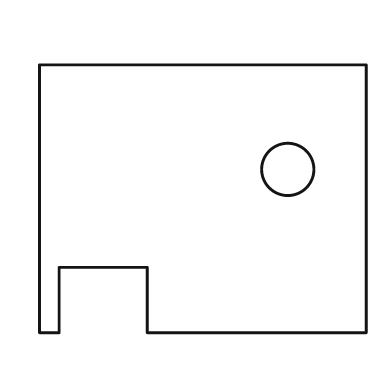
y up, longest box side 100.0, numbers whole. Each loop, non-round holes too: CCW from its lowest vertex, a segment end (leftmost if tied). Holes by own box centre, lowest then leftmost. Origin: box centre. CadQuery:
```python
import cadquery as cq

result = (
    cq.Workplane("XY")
    .moveTo(-50.0, -41.0)
    .lineTo(-44.0, -41.0)
    .lineTo(-44.0, -21.0)
    .lineTo(-17.0, -21.0)
    .lineTo(-17.0, -41.0)
    .lineTo(50.0, -41.0)
    .lineTo(50.0, 41.0)
    .lineTo(-50.0, 41.0)
    .close()
    .moveTo(26.0, 9.0)
    .circle(8.0)
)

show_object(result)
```